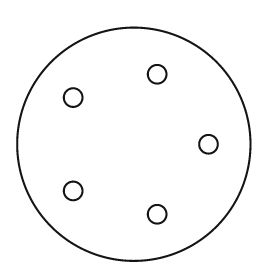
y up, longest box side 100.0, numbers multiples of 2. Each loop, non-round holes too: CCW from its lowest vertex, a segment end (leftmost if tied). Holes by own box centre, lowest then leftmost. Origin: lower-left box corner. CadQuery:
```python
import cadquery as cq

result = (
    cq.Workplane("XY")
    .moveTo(50.0, 50.0)
    .circle(50.0)
    .moveTo(60.0, 20.0)
    .circle(4.0)
    .moveTo(24.0, 30.0)
    .circle(4.0)
    .moveTo(82.0, 50.0)
    .circle(4.0)
    .moveTo(24.0, 70.0)
    .circle(4.0)
    .moveTo(60.0, 80.0)
    .circle(4.0)
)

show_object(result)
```